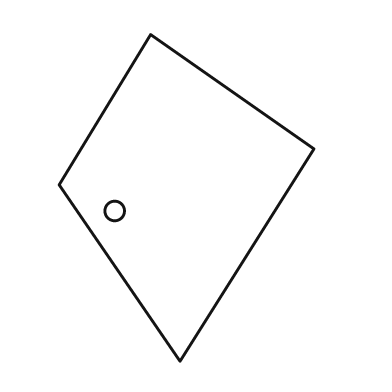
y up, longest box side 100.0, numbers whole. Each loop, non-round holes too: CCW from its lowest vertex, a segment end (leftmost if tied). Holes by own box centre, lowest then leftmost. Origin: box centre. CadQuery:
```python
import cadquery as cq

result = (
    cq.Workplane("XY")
    .moveTo(-2.0, -50.0)
    .lineTo(39.0, 15.0)
    .lineTo(-11.0, 50.0)
    .lineTo(-39.0, 4.0)
    .close()
    .moveTo(-22.0, -4.0)
    .circle(3.0)
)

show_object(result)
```